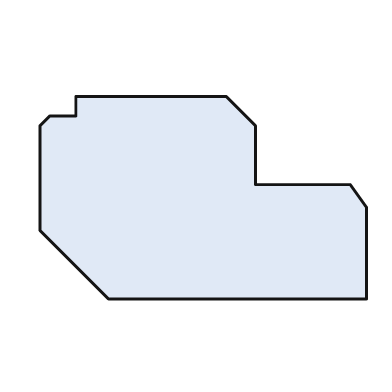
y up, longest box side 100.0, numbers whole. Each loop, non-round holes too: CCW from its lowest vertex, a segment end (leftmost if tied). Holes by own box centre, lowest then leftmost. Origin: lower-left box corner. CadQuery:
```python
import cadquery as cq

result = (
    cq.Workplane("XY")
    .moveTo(21.0, 0.0)
    .lineTo(100.0, 0.0)
    .lineTo(100.0, 28.0)
    .lineTo(95.0, 35.0)
    .lineTo(66.0, 35.0)
    .lineTo(66.0, 53.0)
    .lineTo(57.0, 62.0)
    .lineTo(11.0, 62.0)
    .lineTo(11.0, 56.0)
    .lineTo(3.0, 56.0)
    .lineTo(0.0, 53.0)
    .lineTo(0.0, 21.0)
    .close()
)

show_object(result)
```